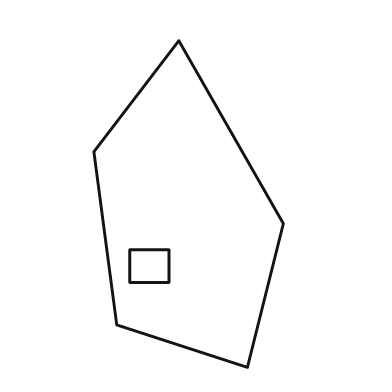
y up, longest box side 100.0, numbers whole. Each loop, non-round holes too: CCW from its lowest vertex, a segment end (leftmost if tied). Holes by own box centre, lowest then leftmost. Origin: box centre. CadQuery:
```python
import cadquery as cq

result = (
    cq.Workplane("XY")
    .moveTo(18.0, -50.0)
    .lineTo(29.0, -6.0)
    .lineTo(-3.0, 50.0)
    .lineTo(-29.0, 16.0)
    .lineTo(-22.0, -37.0)
    .close()
    .moveTo(-18.0, -24.0)
    .lineTo(-6.0, -24.0)
    .lineTo(-6.0, -14.0)
    .lineTo(-18.0, -14.0)
    .close()
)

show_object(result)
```